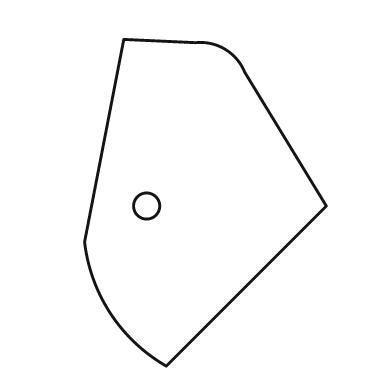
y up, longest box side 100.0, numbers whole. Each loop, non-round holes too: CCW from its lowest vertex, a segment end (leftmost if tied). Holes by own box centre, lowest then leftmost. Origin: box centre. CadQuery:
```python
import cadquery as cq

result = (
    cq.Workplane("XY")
    .moveTo(-12.0, -50.0)
    .lineTo(37.0, -1.0)
    .lineTo(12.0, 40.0)
    .threePointArc((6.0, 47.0), (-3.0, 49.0))
    .lineTo(-25.0, 50.0)
    .lineTo(-37.0, -12.0)
    .threePointArc((-29.0, -34.0), (-12.0, -50.0))
    .close()
    .moveTo(-18.0, -1.0)
    .circle(4.0)
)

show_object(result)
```